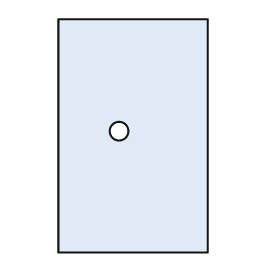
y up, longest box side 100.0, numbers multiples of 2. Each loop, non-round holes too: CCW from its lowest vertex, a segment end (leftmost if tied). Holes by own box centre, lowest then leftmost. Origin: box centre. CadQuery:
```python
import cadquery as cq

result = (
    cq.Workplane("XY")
    .moveTo(-32.0, -50.0)
    .lineTo(32.0, -50.0)
    .lineTo(32.0, 50.0)
    .lineTo(-32.0, 50.0)
    .close()
    .moveTo(-6.0, 2.0)
    .circle(4.0)
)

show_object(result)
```